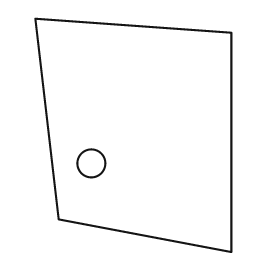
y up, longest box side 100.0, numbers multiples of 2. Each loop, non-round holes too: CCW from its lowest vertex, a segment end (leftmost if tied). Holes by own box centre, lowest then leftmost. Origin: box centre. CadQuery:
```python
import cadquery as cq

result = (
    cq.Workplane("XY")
    .moveTo(42.0, -50.0)
    .lineTo(42.0, 44.0)
    .lineTo(-42.0, 50.0)
    .lineTo(-32.0, -36.0)
    .close()
    .moveTo(-18.0, -12.0)
    .circle(6.0)
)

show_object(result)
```